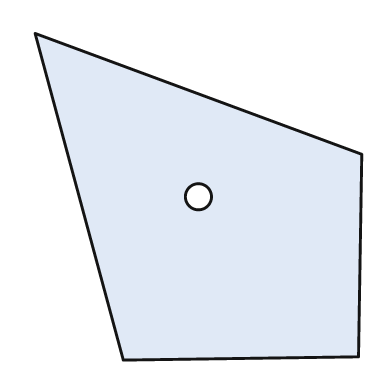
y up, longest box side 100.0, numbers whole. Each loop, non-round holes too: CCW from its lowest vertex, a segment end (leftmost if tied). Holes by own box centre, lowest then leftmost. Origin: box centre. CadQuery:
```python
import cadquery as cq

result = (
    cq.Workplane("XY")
    .moveTo(-23.0, -50.0)
    .lineTo(49.0, -49.0)
    .lineTo(50.0, 13.0)
    .lineTo(-50.0, 50.0)
    .close()
    .moveTo(0.0, 0.0)
    .circle(4.0)
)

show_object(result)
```